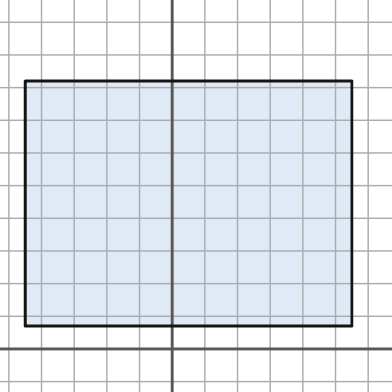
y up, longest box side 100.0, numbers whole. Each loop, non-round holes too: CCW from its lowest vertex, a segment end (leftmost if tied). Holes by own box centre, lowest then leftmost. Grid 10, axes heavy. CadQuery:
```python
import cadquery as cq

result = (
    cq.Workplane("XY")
    .moveTo(-45.0, 7.0)
    .lineTo(55.0, 7.0)
    .lineTo(55.0, 82.0)
    .lineTo(-45.0, 82.0)
    .close()
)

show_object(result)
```